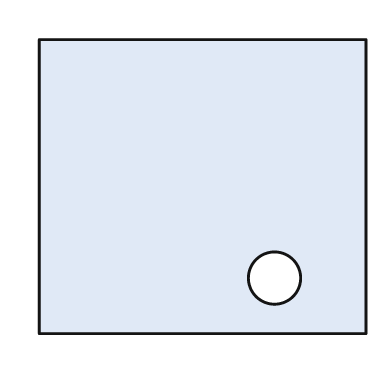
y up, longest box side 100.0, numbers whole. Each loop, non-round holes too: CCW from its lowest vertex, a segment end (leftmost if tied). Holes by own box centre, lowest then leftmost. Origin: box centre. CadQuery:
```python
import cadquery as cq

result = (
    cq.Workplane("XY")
    .moveTo(-50.0, -45.0)
    .lineTo(50.0, -45.0)
    .lineTo(50.0, 45.0)
    .lineTo(-50.0, 45.0)
    .close()
    .moveTo(22.0, -28.0)
    .circle(8.0)
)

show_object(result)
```